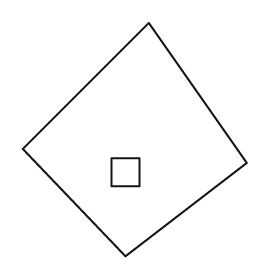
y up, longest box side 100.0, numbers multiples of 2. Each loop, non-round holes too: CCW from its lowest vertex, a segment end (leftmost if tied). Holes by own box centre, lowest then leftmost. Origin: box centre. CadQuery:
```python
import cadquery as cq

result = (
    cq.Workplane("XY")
    .moveTo(-4.0, -50.0)
    .lineTo(48.0, -10.0)
    .lineTo(6.0, 50.0)
    .lineTo(-48.0, -4.0)
    .close()
    .moveTo(-10.0, -20.0)
    .lineTo(2.0, -20.0)
    .lineTo(2.0, -8.0)
    .lineTo(-10.0, -8.0)
    .close()
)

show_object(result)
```